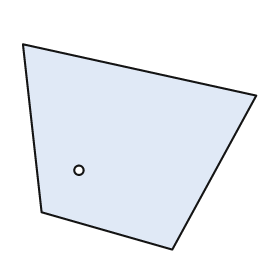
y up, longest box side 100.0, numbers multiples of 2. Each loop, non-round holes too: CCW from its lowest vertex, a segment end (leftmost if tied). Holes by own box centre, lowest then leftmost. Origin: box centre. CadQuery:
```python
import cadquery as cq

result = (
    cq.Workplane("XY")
    .moveTo(14.0, -44.0)
    .lineTo(50.0, 22.0)
    .lineTo(-50.0, 44.0)
    .lineTo(-42.0, -28.0)
    .close()
    .moveTo(-26.0, -10.0)
    .circle(2.0)
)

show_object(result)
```